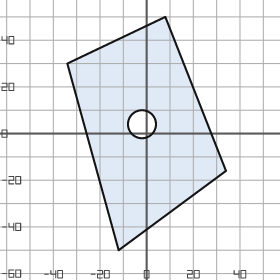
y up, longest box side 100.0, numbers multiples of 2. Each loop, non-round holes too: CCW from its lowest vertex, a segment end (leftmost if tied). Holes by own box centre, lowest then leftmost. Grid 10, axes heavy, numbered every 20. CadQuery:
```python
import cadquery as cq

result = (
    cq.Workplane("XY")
    .moveTo(-12.0, -50.0)
    .lineTo(34.0, -16.0)
    .lineTo(8.0, 50.0)
    .lineTo(-34.0, 30.0)
    .close()
    .moveTo(-2.0, 4.0)
    .circle(6.0)
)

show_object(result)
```